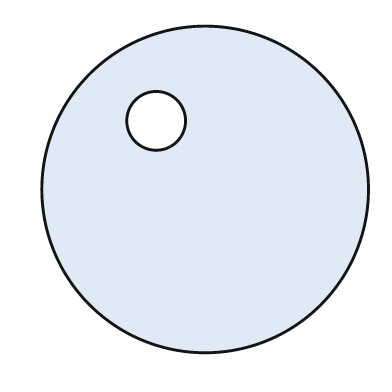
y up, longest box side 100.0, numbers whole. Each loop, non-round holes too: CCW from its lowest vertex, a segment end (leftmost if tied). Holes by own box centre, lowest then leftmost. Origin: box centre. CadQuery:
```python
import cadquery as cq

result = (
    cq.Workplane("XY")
    .moveTo(0.0, 0.0)
    .circle(50.0)
    .moveTo(-15.0, 21.0)
    .circle(9.0)
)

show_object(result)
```